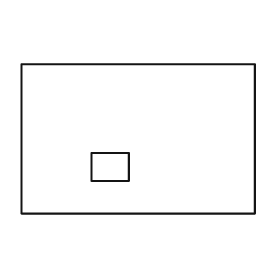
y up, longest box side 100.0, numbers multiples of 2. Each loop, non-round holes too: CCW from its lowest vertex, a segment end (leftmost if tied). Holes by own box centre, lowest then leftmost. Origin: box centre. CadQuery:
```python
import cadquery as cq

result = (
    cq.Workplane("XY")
    .moveTo(-50.0, -32.0)
    .lineTo(50.0, -32.0)
    .lineTo(50.0, 32.0)
    .lineTo(-50.0, 32.0)
    .close()
    .moveTo(-20.0, -18.0)
    .lineTo(-4.0, -18.0)
    .lineTo(-4.0, -6.0)
    .lineTo(-20.0, -6.0)
    .close()
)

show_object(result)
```